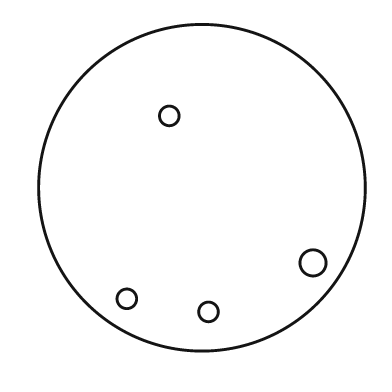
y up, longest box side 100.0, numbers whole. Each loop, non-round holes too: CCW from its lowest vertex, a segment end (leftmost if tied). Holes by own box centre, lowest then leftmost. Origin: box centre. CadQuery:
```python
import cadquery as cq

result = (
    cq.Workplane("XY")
    .moveTo(0.0, 0.0)
    .circle(50.0)
    .moveTo(2.0, -38.0)
    .circle(3.0)
    .moveTo(-23.0, -34.0)
    .circle(3.0)
    .moveTo(34.0, -23.0)
    .circle(4.0)
    .moveTo(-10.0, 22.0)
    .circle(3.0)
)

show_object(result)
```